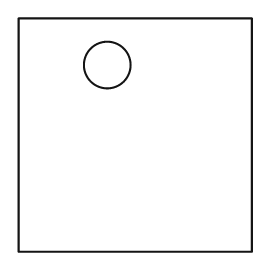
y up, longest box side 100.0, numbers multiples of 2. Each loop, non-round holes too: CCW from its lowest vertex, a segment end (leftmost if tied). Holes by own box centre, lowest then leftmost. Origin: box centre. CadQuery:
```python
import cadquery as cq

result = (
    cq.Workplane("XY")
    .moveTo(-50.0, -50.0)
    .lineTo(50.0, -50.0)
    .lineTo(50.0, 50.0)
    .lineTo(-50.0, 50.0)
    .close()
    .moveTo(-12.0, 30.0)
    .circle(10.0)
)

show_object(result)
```